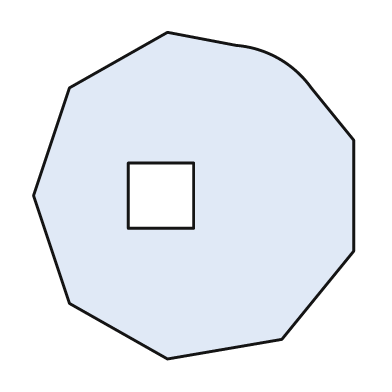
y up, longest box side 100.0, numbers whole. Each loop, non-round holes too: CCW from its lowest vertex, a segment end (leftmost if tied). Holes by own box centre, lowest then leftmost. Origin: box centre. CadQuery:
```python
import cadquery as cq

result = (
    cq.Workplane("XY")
    .moveTo(-8.0, -50.0)
    .lineTo(27.0, -44.0)
    .lineTo(49.0, -17.0)
    .lineTo(49.0, 17.0)
    .lineTo(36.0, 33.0)
    .threePointArc((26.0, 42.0), (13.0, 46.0))
    .lineTo(-8.0, 50.0)
    .lineTo(-38.0, 33.0)
    .lineTo(-49.0, 0.0)
    .lineTo(-38.0, -33.0)
    .close()
    .moveTo(-20.0, -10.0)
    .lineTo(0.0, -10.0)
    .lineTo(0.0, 10.0)
    .lineTo(-20.0, 10.0)
    .close()
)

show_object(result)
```